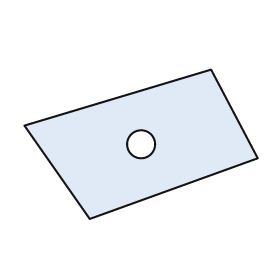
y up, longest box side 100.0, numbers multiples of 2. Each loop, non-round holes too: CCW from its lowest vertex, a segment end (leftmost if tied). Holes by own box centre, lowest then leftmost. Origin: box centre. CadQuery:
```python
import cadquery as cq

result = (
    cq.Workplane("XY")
    .moveTo(-22.0, -32.0)
    .lineTo(50.0, -6.0)
    .lineTo(30.0, 32.0)
    .lineTo(-50.0, 8.0)
    .close()
    .moveTo(0.0, 0.0)
    .circle(6.0)
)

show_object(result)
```